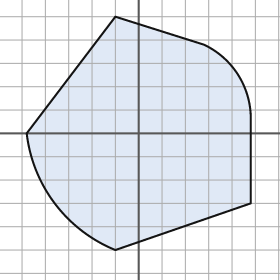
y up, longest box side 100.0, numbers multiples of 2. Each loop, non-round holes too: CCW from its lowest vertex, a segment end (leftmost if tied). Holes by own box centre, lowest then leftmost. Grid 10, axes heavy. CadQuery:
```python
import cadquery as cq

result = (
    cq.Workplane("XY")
    .moveTo(-10.0, -50.0)
    .lineTo(48.0, -30.0)
    .lineTo(48.0, 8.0)
    .threePointArc((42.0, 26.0), (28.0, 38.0))
    .lineTo(-10.0, 50.0)
    .lineTo(-48.0, 0.0)
    .threePointArc((-36.0, -30.0), (-10.0, -50.0))
    .close()
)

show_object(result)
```